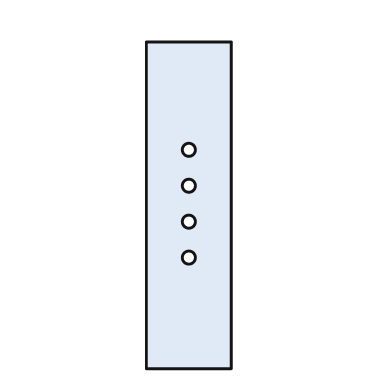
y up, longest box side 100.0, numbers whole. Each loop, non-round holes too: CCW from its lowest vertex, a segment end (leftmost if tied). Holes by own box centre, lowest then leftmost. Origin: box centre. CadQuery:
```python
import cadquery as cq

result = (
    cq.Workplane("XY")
    .moveTo(-13.0, -50.0)
    .lineTo(13.0, -50.0)
    .lineTo(13.0, 50.0)
    .lineTo(-13.0, 50.0)
    .close()
    .moveTo(0.0, -16.0)
    .circle(2.0)
    .moveTo(0.0, -5.0)
    .circle(2.0)
    .moveTo(0.0, 6.0)
    .circle(2.0)
    .moveTo(0.0, 17.0)
    .circle(2.0)
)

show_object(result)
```